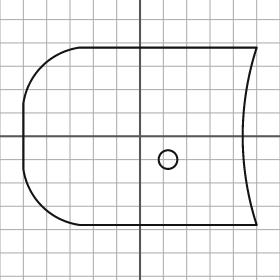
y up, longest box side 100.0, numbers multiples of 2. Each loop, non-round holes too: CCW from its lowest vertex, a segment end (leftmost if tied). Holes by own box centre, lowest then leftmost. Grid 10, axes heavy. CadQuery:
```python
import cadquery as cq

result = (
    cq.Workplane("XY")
    .moveTo(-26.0, -38.0)
    .lineTo(50.0, -38.0)
    .threePointArc((44.0, 0.0), (50.0, 38.0))
    .lineTo(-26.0, 38.0)
    .threePointArc((-42.0, 30.0), (-50.0, 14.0))
    .lineTo(-50.0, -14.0)
    .threePointArc((-42.0, -30.0), (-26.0, -38.0))
    .close()
    .moveTo(12.0, -10.0)
    .circle(4.0)
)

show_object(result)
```